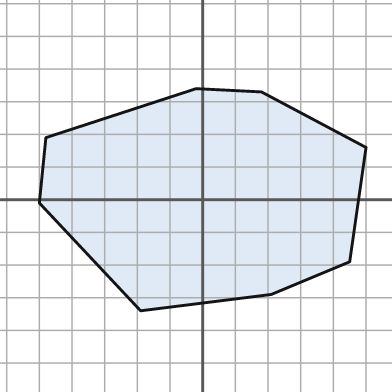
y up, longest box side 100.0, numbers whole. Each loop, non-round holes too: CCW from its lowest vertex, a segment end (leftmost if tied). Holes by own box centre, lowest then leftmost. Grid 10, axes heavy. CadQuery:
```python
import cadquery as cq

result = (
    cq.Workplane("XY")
    .moveTo(-19.0, -34.0)
    .lineTo(21.0, -29.0)
    .lineTo(45.0, -19.0)
    .lineTo(50.0, 16.0)
    .lineTo(18.0, 33.0)
    .lineTo(-2.0, 34.0)
    .lineTo(-48.0, 19.0)
    .lineTo(-50.0, -1.0)
    .close()
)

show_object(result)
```